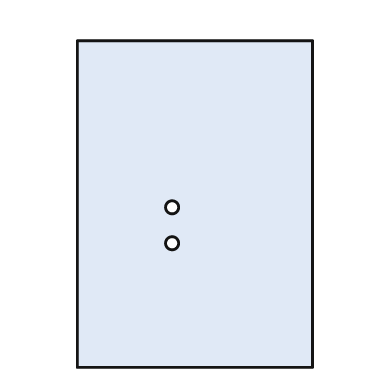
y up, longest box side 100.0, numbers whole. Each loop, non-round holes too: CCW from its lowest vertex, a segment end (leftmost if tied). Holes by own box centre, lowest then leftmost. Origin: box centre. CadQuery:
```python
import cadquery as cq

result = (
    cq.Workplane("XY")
    .moveTo(-36.0, -50.0)
    .lineTo(36.0, -50.0)
    .lineTo(36.0, 50.0)
    .lineTo(-36.0, 50.0)
    .close()
    .moveTo(-7.0, -12.0)
    .circle(2.0)
    .moveTo(-7.0, -1.0)
    .circle(2.0)
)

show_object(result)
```